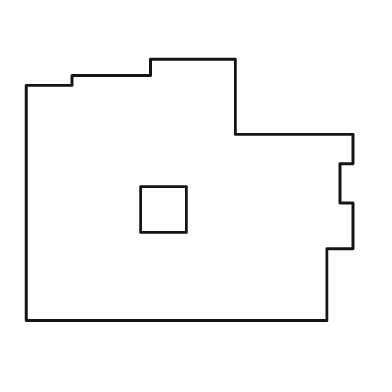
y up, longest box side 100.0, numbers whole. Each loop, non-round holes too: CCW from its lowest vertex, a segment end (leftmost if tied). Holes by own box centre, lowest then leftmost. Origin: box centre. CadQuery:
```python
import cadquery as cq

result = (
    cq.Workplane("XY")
    .moveTo(-50.0, -40.0)
    .lineTo(42.0, -40.0)
    .lineTo(42.0, -18.0)
    .lineTo(50.0, -18.0)
    .lineTo(50.0, -4.0)
    .lineTo(46.0, -4.0)
    .lineTo(46.0, 8.0)
    .lineTo(50.0, 8.0)
    .lineTo(50.0, 17.0)
    .lineTo(14.0, 17.0)
    .lineTo(14.0, 40.0)
    .lineTo(-12.0, 40.0)
    .lineTo(-12.0, 35.0)
    .lineTo(-36.0, 35.0)
    .lineTo(-36.0, 32.0)
    .lineTo(-50.0, 32.0)
    .close()
    .moveTo(-15.0, -13.0)
    .lineTo(-1.0, -13.0)
    .lineTo(-1.0, 1.0)
    .lineTo(-15.0, 1.0)
    .close()
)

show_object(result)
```